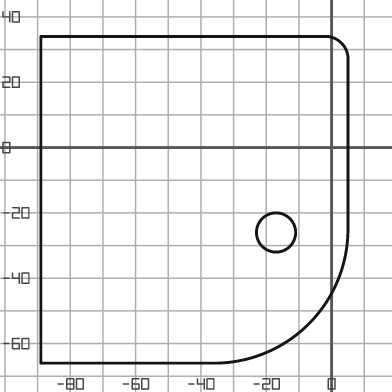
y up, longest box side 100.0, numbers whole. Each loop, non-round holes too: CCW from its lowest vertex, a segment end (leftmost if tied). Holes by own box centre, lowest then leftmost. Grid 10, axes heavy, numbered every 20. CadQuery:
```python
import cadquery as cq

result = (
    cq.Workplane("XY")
    .moveTo(-89.0, -66.0)
    .lineTo(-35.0, -66.0)
    .threePointArc((-7.0, -54.0), (5.0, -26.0))
    .lineTo(5.0, 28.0)
    .threePointArc((3.0, 32.0), (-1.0, 34.0))
    .lineTo(-89.0, 34.0)
    .close()
    .moveTo(-17.0, -26.0)
    .circle(6.0)
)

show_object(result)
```